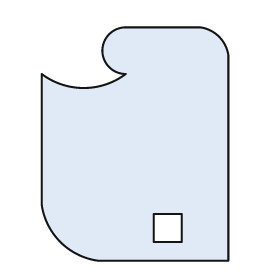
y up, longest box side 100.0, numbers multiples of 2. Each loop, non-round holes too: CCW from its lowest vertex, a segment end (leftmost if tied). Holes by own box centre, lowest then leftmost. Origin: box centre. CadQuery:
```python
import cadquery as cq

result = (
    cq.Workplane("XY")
    .moveTo(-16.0, -50.0)
    .lineTo(40.0, -50.0)
    .lineTo(40.0, 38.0)
    .threePointArc((36.0, 46.0), (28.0, 50.0))
    .lineTo(-4.0, 50.0)
    .threePointArc((-14.0, 40.0), (-4.0, 30.0))
    .threePointArc((-22.0, 24.0), (-40.0, 30.0))
    .lineTo(-40.0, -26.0)
    .threePointArc((-32.0, -42.0), (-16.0, -50.0))
    .close()
    .moveTo(8.0, -42.0)
    .lineTo(20.0, -42.0)
    .lineTo(20.0, -30.0)
    .lineTo(8.0, -30.0)
    .close()
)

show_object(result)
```